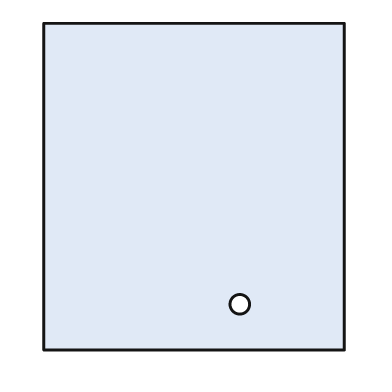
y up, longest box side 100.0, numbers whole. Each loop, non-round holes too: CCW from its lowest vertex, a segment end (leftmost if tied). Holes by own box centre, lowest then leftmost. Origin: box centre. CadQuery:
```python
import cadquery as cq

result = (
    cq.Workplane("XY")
    .moveTo(-46.0, -50.0)
    .lineTo(46.0, -50.0)
    .lineTo(46.0, 50.0)
    .lineTo(-46.0, 50.0)
    .close()
    .moveTo(14.0, -36.0)
    .circle(3.0)
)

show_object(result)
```